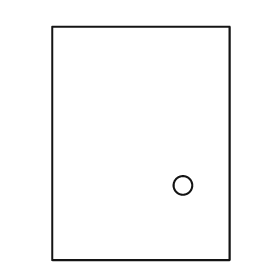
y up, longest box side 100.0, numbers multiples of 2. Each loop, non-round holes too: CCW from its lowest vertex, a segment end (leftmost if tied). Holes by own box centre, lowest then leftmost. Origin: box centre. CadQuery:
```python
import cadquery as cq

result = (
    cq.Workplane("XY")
    .moveTo(-38.0, -50.0)
    .lineTo(38.0, -50.0)
    .lineTo(38.0, 50.0)
    .lineTo(-38.0, 50.0)
    .close()
    .moveTo(18.0, -18.0)
    .circle(4.0)
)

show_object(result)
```